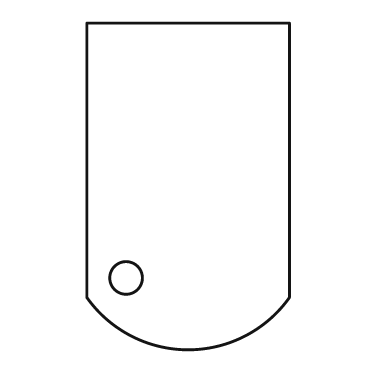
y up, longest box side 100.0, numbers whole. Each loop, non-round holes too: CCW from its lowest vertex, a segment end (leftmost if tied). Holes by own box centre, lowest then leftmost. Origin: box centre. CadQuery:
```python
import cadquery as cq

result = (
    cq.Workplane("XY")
    .moveTo(-31.0, -34.0)
    .threePointArc((0.0, -50.0), (31.0, -34.0))
    .lineTo(31.0, 50.0)
    .lineTo(-31.0, 50.0)
    .close()
    .moveTo(-19.0, -28.0)
    .circle(5.0)
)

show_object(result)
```